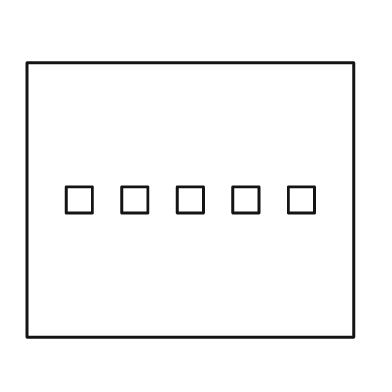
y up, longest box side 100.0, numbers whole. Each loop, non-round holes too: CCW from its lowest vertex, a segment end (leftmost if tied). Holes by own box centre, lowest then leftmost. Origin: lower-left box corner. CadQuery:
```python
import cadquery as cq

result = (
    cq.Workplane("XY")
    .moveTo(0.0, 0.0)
    .lineTo(100.0, 0.0)
    .lineTo(100.0, 84.0)
    .lineTo(0.0, 84.0)
    .close()
    .moveTo(12.0, 38.0)
    .lineTo(20.0, 38.0)
    .lineTo(20.0, 46.0)
    .lineTo(12.0, 46.0)
    .close()
    .moveTo(29.0, 38.0)
    .lineTo(37.0, 38.0)
    .lineTo(37.0, 46.0)
    .lineTo(29.0, 46.0)
    .close()
    .moveTo(46.0, 38.0)
    .lineTo(54.0, 38.0)
    .lineTo(54.0, 46.0)
    .lineTo(46.0, 46.0)
    .close()
    .moveTo(63.0, 38.0)
    .lineTo(71.0, 38.0)
    .lineTo(71.0, 46.0)
    .lineTo(63.0, 46.0)
    .close()
    .moveTo(80.0, 38.0)
    .lineTo(88.0, 38.0)
    .lineTo(88.0, 46.0)
    .lineTo(80.0, 46.0)
    .close()
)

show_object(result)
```